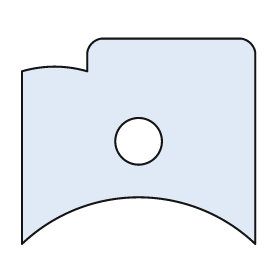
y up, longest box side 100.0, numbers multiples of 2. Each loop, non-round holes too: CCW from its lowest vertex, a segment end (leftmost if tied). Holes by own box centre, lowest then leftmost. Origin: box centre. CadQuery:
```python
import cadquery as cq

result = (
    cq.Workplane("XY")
    .moveTo(-50.0, -44.0)
    .threePointArc((0.0, -24.0), (50.0, -44.0))
    .lineTo(50.0, 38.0)
    .threePointArc((48.0, 42.0), (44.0, 44.0))
    .lineTo(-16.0, 44.0)
    .threePointArc((-20.0, 42.0), (-22.0, 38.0))
    .lineTo(-22.0, 30.0)
    .threePointArc((-36.0, 32.0), (-50.0, 30.0))
    .close()
    .moveTo(0.0, 0.0)
    .circle(10.0)
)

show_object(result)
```